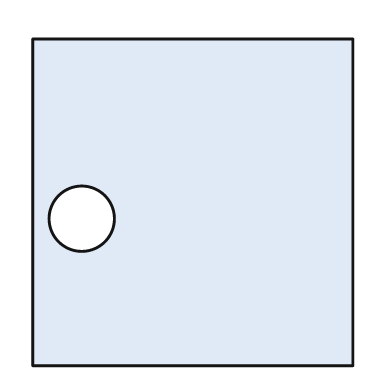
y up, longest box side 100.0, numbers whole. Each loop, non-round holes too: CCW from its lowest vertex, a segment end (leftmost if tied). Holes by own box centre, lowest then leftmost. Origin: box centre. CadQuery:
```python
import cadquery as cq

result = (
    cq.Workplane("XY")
    .moveTo(-49.0, -50.0)
    .lineTo(49.0, -50.0)
    .lineTo(49.0, 50.0)
    .lineTo(-49.0, 50.0)
    .close()
    .moveTo(-34.0, -5.0)
    .circle(10.0)
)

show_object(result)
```